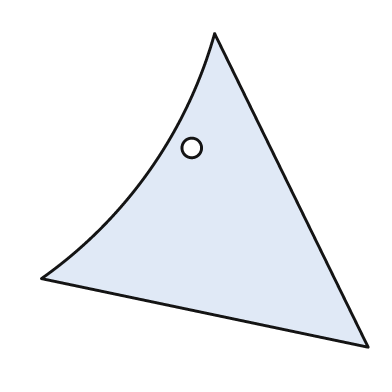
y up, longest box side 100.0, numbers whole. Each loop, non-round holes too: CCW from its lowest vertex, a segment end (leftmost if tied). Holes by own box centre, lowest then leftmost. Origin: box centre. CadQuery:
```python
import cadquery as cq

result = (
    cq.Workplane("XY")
    .moveTo(50.0, -48.0)
    .lineTo(3.0, 48.0)
    .threePointArc((-17.0, 6.0), (-50.0, -27.0))
    .close()
    .moveTo(-4.0, 13.0)
    .circle(3.0)
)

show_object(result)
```